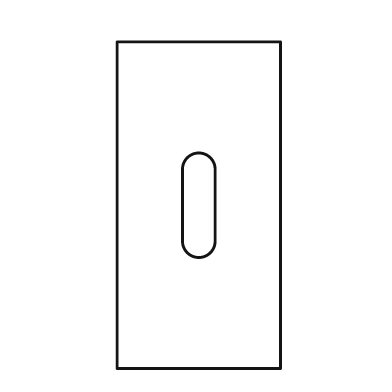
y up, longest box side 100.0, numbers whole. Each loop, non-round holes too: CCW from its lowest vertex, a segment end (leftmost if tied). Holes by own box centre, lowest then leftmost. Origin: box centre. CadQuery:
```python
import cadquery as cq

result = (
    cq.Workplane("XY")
    .moveTo(-25.0, -50.0)
    .lineTo(25.0, -50.0)
    .lineTo(25.0, 50.0)
    .lineTo(-25.0, 50.0)
    .close()
    .moveTo(-5.0, -11.0)
    .threePointArc((0.0, -16.0), (5.0, -11.0))
    .lineTo(5.0, 11.0)
    .threePointArc((0.0, 16.0), (-5.0, 11.0))
    .close()
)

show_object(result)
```